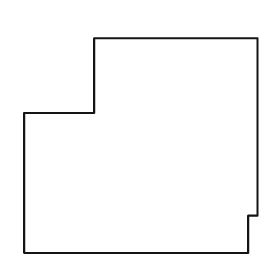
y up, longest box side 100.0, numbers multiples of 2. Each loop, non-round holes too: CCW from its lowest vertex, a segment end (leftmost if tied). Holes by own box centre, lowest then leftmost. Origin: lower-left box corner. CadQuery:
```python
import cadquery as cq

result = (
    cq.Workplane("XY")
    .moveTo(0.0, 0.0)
    .lineTo(96.0, 0.0)
    .lineTo(96.0, 16.0)
    .lineTo(100.0, 16.0)
    .lineTo(100.0, 92.0)
    .lineTo(30.0, 92.0)
    .lineTo(30.0, 60.0)
    .lineTo(0.0, 60.0)
    .close()
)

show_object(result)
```